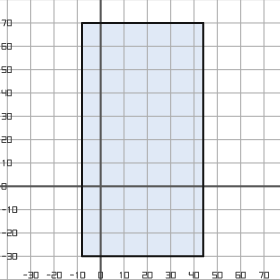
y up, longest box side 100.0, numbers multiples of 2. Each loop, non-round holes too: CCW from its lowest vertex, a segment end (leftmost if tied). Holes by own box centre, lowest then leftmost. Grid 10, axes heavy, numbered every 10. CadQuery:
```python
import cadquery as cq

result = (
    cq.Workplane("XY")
    .moveTo(-8.0, -30.0)
    .lineTo(44.0, -30.0)
    .lineTo(44.0, 70.0)
    .lineTo(-8.0, 70.0)
    .close()
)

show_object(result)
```